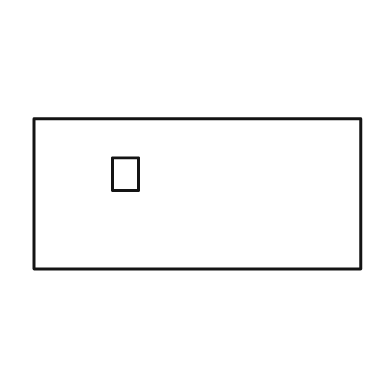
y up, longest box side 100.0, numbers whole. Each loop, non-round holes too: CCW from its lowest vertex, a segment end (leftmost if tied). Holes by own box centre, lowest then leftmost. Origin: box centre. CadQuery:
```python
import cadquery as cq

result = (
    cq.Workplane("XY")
    .moveTo(-50.0, -23.0)
    .lineTo(50.0, -23.0)
    .lineTo(50.0, 23.0)
    .lineTo(-50.0, 23.0)
    .close()
    .moveTo(-26.0, 1.0)
    .lineTo(-18.0, 1.0)
    .lineTo(-18.0, 11.0)
    .lineTo(-26.0, 11.0)
    .close()
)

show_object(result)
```